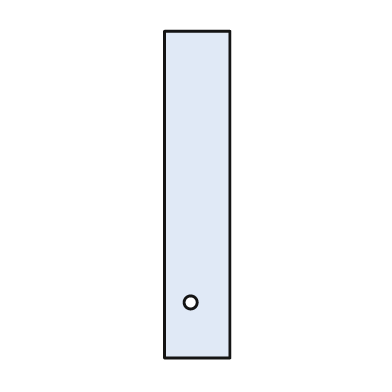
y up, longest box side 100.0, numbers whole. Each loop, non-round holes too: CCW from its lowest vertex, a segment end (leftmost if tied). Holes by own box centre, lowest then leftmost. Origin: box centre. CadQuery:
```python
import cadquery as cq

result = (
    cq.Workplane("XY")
    .moveTo(-10.0, -50.0)
    .lineTo(10.0, -50.0)
    .lineTo(10.0, 50.0)
    .lineTo(-10.0, 50.0)
    .close()
    .moveTo(-2.0, -33.0)
    .circle(2.0)
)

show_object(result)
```